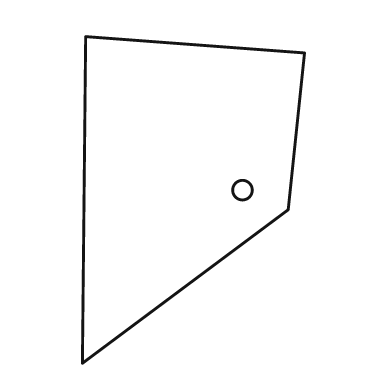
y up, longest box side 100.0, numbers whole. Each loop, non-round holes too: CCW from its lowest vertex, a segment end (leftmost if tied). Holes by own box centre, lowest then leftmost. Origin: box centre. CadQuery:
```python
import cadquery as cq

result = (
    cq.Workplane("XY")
    .moveTo(-34.0, -50.0)
    .lineTo(29.0, -3.0)
    .lineTo(34.0, 45.0)
    .lineTo(-33.0, 50.0)
    .close()
    .moveTo(15.0, 3.0)
    .circle(3.0)
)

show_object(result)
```